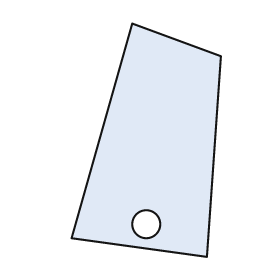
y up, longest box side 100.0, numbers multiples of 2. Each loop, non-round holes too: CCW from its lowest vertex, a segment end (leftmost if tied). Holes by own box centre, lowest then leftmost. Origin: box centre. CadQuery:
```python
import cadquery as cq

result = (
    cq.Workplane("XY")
    .moveTo(26.0, -50.0)
    .lineTo(32.0, 36.0)
    .lineTo(-6.0, 50.0)
    .lineTo(-32.0, -42.0)
    .close()
    .moveTo(0.0, -36.0)
    .circle(6.0)
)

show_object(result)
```